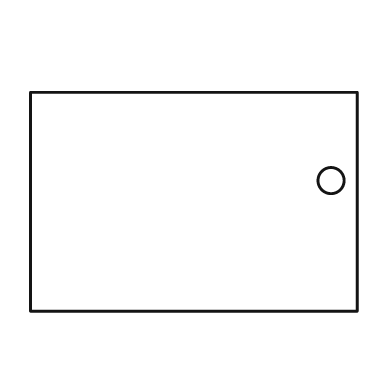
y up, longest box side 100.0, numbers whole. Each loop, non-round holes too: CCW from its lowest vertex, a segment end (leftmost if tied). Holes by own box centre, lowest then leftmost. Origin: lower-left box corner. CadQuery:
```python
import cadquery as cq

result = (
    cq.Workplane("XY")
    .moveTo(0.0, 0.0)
    .lineTo(100.0, 0.0)
    .lineTo(100.0, 67.0)
    .lineTo(0.0, 67.0)
    .close()
    .moveTo(92.0, 40.0)
    .circle(4.0)
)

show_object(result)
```